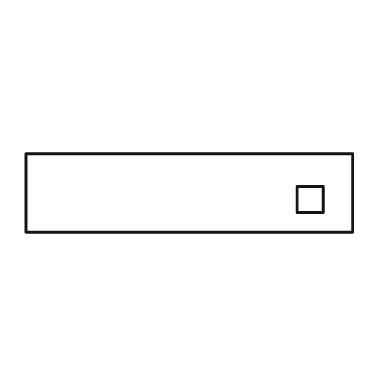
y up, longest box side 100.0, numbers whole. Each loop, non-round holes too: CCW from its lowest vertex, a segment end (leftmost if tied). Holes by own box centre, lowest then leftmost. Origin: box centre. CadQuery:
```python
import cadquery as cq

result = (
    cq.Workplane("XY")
    .moveTo(-50.0, -12.0)
    .lineTo(50.0, -12.0)
    .lineTo(50.0, 12.0)
    .lineTo(-50.0, 12.0)
    .close()
    .moveTo(33.0, -6.0)
    .lineTo(41.0, -6.0)
    .lineTo(41.0, 2.0)
    .lineTo(33.0, 2.0)
    .close()
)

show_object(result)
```